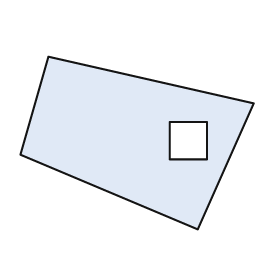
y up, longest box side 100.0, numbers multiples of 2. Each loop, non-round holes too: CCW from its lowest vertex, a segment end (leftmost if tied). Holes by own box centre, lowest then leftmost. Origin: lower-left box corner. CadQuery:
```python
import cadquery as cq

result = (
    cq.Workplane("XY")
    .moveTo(76.0, 0.0)
    .lineTo(100.0, 54.0)
    .lineTo(12.0, 74.0)
    .lineTo(0.0, 32.0)
    .close()
    .moveTo(64.0, 30.0)
    .lineTo(80.0, 30.0)
    .lineTo(80.0, 46.0)
    .lineTo(64.0, 46.0)
    .close()
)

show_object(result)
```